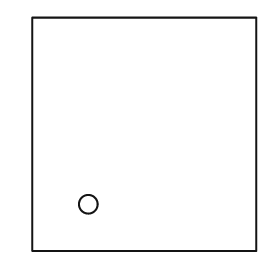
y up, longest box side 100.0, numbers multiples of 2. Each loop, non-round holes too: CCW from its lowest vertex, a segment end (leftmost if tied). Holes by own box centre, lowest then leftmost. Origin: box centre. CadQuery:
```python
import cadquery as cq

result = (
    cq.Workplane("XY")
    .moveTo(-48.0, -50.0)
    .lineTo(48.0, -50.0)
    .lineTo(48.0, 50.0)
    .lineTo(-48.0, 50.0)
    .close()
    .moveTo(-24.0, -30.0)
    .circle(4.0)
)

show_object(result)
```